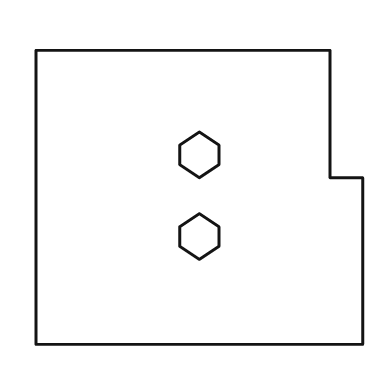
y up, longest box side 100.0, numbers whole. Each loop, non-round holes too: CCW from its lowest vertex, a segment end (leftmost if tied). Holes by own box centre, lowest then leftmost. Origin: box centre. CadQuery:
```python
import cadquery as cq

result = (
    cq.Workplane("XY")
    .moveTo(-50.0, -45.0)
    .lineTo(50.0, -45.0)
    .lineTo(50.0, 6.0)
    .lineTo(40.0, 6.0)
    .lineTo(40.0, 45.0)
    .lineTo(-50.0, 45.0)
    .close()
    .moveTo(0.0, -19.0)
    .lineTo(6.0, -15.0)
    .lineTo(6.0, -9.0)
    .lineTo(0.0, -5.0)
    .lineTo(-6.0, -9.0)
    .lineTo(-6.0, -15.0)
    .close()
    .moveTo(0.0, 6.0)
    .lineTo(6.0, 10.0)
    .lineTo(6.0, 16.0)
    .lineTo(0.0, 20.0)
    .lineTo(-6.0, 16.0)
    .lineTo(-6.0, 10.0)
    .close()
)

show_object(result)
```